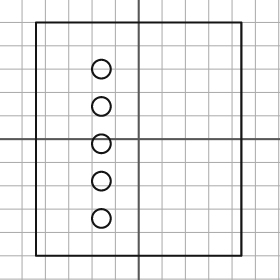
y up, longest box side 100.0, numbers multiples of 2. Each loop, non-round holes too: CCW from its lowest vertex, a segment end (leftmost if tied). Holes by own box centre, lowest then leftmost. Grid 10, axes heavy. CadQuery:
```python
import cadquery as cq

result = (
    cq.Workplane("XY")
    .moveTo(-44.0, -50.0)
    .lineTo(44.0, -50.0)
    .lineTo(44.0, 50.0)
    .lineTo(-44.0, 50.0)
    .close()
    .moveTo(-16.0, -34.0)
    .circle(4.0)
    .moveTo(-16.0, -18.0)
    .circle(4.0)
    .moveTo(-16.0, -2.0)
    .circle(4.0)
    .moveTo(-16.0, 14.0)
    .circle(4.0)
    .moveTo(-16.0, 30.0)
    .circle(4.0)
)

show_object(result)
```